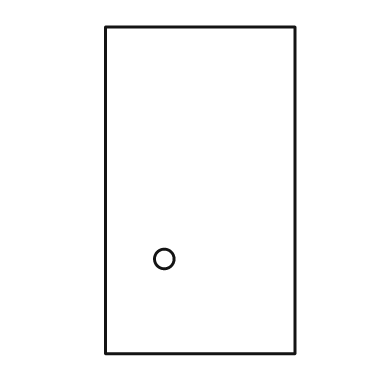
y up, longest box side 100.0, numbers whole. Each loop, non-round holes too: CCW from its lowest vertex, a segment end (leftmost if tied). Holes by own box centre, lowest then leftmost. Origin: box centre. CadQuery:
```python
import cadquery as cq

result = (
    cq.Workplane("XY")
    .moveTo(-29.0, -50.0)
    .lineTo(29.0, -50.0)
    .lineTo(29.0, 50.0)
    .lineTo(-29.0, 50.0)
    .close()
    .moveTo(-11.0, -21.0)
    .circle(3.0)
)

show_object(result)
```